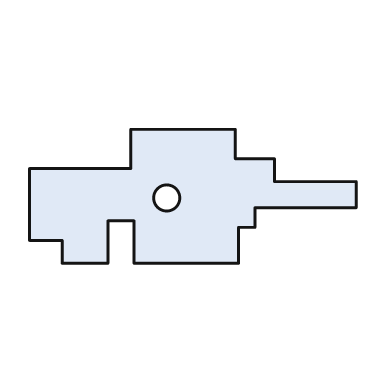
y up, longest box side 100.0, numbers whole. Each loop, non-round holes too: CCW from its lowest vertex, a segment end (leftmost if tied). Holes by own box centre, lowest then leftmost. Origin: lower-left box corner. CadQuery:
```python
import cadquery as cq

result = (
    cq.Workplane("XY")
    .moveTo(10.0, 0.0)
    .lineTo(24.0, 0.0)
    .lineTo(24.0, 13.0)
    .lineTo(32.0, 13.0)
    .lineTo(32.0, 0.0)
    .lineTo(64.0, 0.0)
    .lineTo(64.0, 11.0)
    .lineTo(69.0, 11.0)
    .lineTo(69.0, 17.0)
    .lineTo(100.0, 17.0)
    .lineTo(100.0, 25.0)
    .lineTo(75.0, 25.0)
    .lineTo(75.0, 32.0)
    .lineTo(63.0, 32.0)
    .lineTo(63.0, 41.0)
    .lineTo(31.0, 41.0)
    .lineTo(31.0, 29.0)
    .lineTo(0.0, 29.0)
    .lineTo(0.0, 7.0)
    .lineTo(10.0, 7.0)
    .close()
    .moveTo(42.0, 20.0)
    .circle(4.0)
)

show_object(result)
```